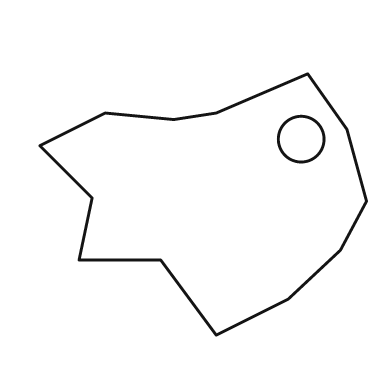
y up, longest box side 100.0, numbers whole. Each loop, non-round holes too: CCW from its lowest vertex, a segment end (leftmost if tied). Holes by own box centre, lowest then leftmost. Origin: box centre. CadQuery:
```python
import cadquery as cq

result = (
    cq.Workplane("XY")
    .moveTo(4.0, -40.0)
    .lineTo(26.0, -29.0)
    .lineTo(42.0, -14.0)
    .lineTo(50.0, 1.0)
    .lineTo(44.0, 23.0)
    .lineTo(32.0, 40.0)
    .lineTo(4.0, 28.0)
    .lineTo(-9.0, 26.0)
    .lineTo(-30.0, 28.0)
    .lineTo(-50.0, 18.0)
    .lineTo(-34.0, 2.0)
    .lineTo(-38.0, -17.0)
    .lineTo(-13.0, -17.0)
    .close()
    .moveTo(30.0, 20.0)
    .circle(7.0)
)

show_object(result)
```